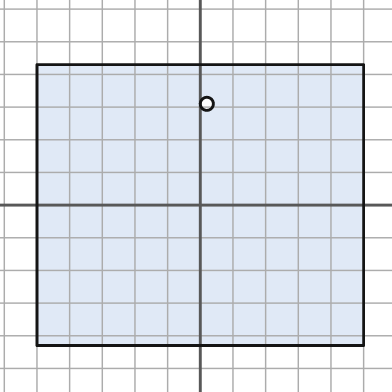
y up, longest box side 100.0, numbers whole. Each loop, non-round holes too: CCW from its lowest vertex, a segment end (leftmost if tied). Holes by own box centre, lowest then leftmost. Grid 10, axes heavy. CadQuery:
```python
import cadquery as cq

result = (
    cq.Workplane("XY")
    .moveTo(-50.0, -43.0)
    .lineTo(50.0, -43.0)
    .lineTo(50.0, 43.0)
    .lineTo(-50.0, 43.0)
    .close()
    .moveTo(2.0, 31.0)
    .circle(2.0)
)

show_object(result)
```